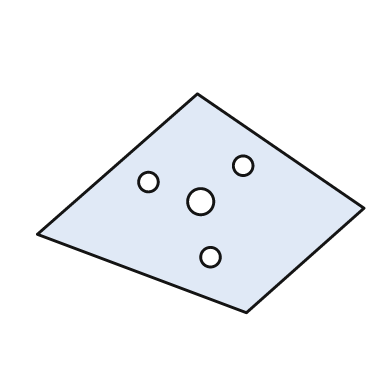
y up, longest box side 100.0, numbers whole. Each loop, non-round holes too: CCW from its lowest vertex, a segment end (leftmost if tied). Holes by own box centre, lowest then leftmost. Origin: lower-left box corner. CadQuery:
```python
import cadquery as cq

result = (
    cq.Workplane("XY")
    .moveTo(64.0, 0.0)
    .lineTo(100.0, 32.0)
    .lineTo(49.0, 67.0)
    .lineTo(0.0, 24.0)
    .close()
    .moveTo(53.0, 17.0)
    .circle(3.0)
    .moveTo(50.0, 34.0)
    .circle(4.0)
    .moveTo(34.0, 40.0)
    .circle(3.0)
    .moveTo(63.0, 45.0)
    .circle(3.0)
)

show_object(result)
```